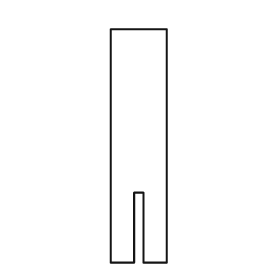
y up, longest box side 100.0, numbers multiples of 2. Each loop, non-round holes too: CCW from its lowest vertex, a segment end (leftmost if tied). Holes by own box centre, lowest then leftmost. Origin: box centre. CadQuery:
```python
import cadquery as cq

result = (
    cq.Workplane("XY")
    .moveTo(-12.0, -50.0)
    .lineTo(-2.0, -50.0)
    .lineTo(-2.0, -20.0)
    .lineTo(2.0, -20.0)
    .lineTo(2.0, -50.0)
    .lineTo(12.0, -50.0)
    .lineTo(12.0, 50.0)
    .lineTo(-12.0, 50.0)
    .close()
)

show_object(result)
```